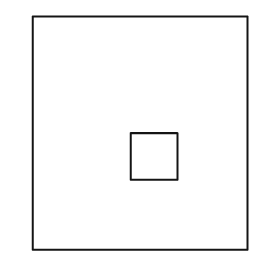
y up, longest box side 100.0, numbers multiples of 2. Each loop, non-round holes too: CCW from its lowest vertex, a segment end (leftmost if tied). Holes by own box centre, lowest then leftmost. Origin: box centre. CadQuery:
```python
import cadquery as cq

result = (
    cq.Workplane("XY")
    .moveTo(-46.0, -50.0)
    .lineTo(46.0, -50.0)
    .lineTo(46.0, 50.0)
    .lineTo(-46.0, 50.0)
    .close()
    .moveTo(-4.0, -20.0)
    .lineTo(16.0, -20.0)
    .lineTo(16.0, 0.0)
    .lineTo(-4.0, 0.0)
    .close()
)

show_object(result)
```